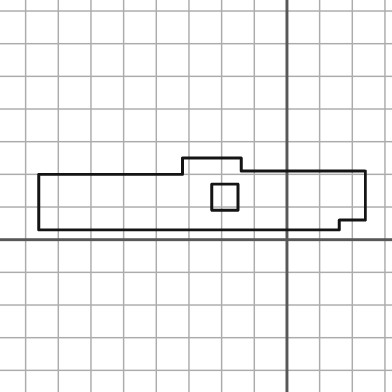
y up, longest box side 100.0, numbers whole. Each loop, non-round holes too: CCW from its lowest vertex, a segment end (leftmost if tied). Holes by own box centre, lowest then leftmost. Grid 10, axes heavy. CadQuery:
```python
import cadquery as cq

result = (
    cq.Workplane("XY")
    .moveTo(-76.0, 3.0)
    .lineTo(16.0, 3.0)
    .lineTo(16.0, 6.0)
    .lineTo(24.0, 6.0)
    .lineTo(24.0, 21.0)
    .lineTo(-14.0, 21.0)
    .lineTo(-14.0, 25.0)
    .lineTo(-32.0, 25.0)
    .lineTo(-32.0, 20.0)
    .lineTo(-76.0, 20.0)
    .close()
    .moveTo(-23.0, 9.0)
    .lineTo(-15.0, 9.0)
    .lineTo(-15.0, 17.0)
    .lineTo(-23.0, 17.0)
    .close()
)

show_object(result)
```